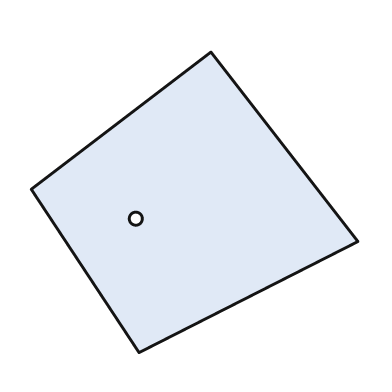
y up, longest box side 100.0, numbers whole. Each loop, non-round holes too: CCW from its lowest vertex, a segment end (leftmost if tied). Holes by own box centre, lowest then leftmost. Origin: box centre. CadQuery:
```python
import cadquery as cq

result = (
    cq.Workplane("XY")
    .moveTo(-17.0, -46.0)
    .lineTo(50.0, -12.0)
    .lineTo(5.0, 46.0)
    .lineTo(-50.0, 4.0)
    .close()
    .moveTo(-18.0, -5.0)
    .circle(2.0)
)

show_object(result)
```